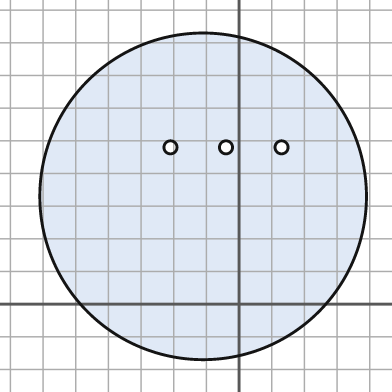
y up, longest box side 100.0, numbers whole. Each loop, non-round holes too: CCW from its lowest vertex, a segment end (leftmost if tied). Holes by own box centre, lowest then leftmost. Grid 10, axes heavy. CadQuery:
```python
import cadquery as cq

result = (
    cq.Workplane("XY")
    .moveTo(-11.0, 33.0)
    .circle(50.0)
    .moveTo(-21.0, 48.0)
    .circle(2.0)
    .moveTo(-4.0, 48.0)
    .circle(2.0)
    .moveTo(13.0, 48.0)
    .circle(2.0)
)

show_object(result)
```